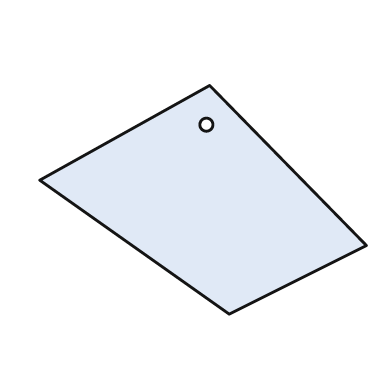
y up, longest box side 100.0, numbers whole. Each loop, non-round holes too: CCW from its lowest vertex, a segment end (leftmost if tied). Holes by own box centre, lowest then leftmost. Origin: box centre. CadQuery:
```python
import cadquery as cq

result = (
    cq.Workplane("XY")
    .moveTo(8.0, -35.0)
    .lineTo(50.0, -14.0)
    .lineTo(2.0, 35.0)
    .lineTo(-50.0, 6.0)
    .close()
    .moveTo(1.0, 23.0)
    .circle(2.0)
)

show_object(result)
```